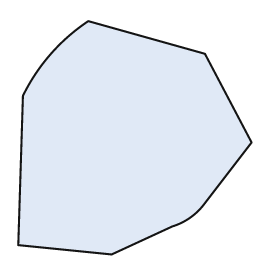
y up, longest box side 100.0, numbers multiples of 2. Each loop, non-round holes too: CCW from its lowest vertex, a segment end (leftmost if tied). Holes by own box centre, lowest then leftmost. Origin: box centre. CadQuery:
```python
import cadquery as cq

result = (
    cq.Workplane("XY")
    .moveTo(-10.0, -50.0)
    .lineTo(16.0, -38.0)
    .threePointArc((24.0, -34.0), (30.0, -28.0))
    .lineTo(50.0, -2.0)
    .lineTo(30.0, 36.0)
    .lineTo(-20.0, 50.0)
    .threePointArc((-36.0, 36.0), (-48.0, 18.0))
    .lineTo(-50.0, -46.0)
    .close()
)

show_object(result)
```